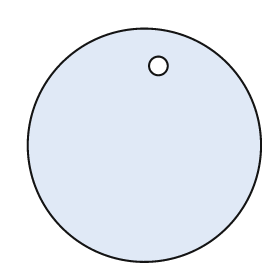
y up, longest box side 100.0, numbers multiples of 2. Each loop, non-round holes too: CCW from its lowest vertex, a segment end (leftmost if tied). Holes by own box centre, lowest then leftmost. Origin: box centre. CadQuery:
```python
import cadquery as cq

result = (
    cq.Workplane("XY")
    .moveTo(0.0, 0.0)
    .circle(50.0)
    .moveTo(6.0, 34.0)
    .circle(4.0)
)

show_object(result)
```